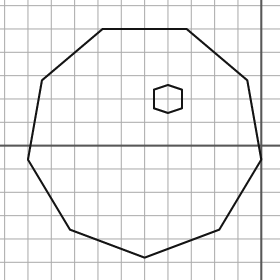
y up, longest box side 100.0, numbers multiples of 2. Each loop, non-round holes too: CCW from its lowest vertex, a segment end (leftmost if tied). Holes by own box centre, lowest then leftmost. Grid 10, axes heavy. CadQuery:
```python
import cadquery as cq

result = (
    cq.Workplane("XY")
    .moveTo(-50.0, -48.0)
    .lineTo(-18.0, -36.0)
    .lineTo(0.0, -6.0)
    .lineTo(-6.0, 28.0)
    .lineTo(-32.0, 50.0)
    .lineTo(-68.0, 50.0)
    .lineTo(-94.0, 28.0)
    .lineTo(-100.0, -6.0)
    .lineTo(-82.0, -36.0)
    .close()
    .moveTo(-40.0, 14.0)
    .lineTo(-34.0, 16.0)
    .lineTo(-34.0, 24.0)
    .lineTo(-40.0, 26.0)
    .lineTo(-46.0, 24.0)
    .lineTo(-46.0, 16.0)
    .close()
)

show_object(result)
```